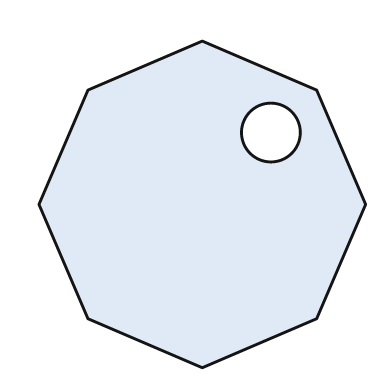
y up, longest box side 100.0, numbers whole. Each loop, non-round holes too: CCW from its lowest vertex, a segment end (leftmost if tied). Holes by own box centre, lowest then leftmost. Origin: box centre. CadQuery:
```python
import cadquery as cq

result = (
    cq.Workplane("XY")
    .moveTo(0.0, -50.0)
    .lineTo(35.0, -35.0)
    .lineTo(50.0, 0.0)
    .lineTo(35.0, 35.0)
    .lineTo(0.0, 50.0)
    .lineTo(-35.0, 35.0)
    .lineTo(-50.0, 0.0)
    .lineTo(-35.0, -35.0)
    .close()
    .moveTo(21.0, 22.0)
    .circle(9.0)
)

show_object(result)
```